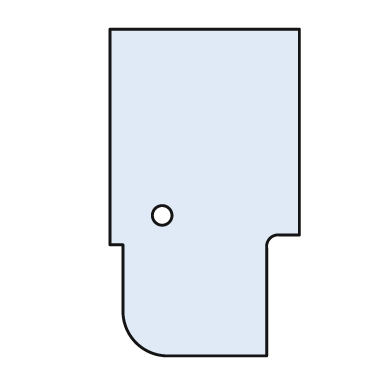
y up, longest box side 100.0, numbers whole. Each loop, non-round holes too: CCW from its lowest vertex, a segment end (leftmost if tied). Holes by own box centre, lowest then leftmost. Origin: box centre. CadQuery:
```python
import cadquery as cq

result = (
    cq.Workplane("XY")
    .moveTo(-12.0, -50.0)
    .lineTo(19.0, -50.0)
    .lineTo(19.0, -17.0)
    .threePointArc((20.0, -14.0), (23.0, -13.0))
    .lineTo(29.0, -13.0)
    .lineTo(29.0, 50.0)
    .lineTo(-29.0, 50.0)
    .lineTo(-29.0, -16.0)
    .lineTo(-25.0, -16.0)
    .lineTo(-25.0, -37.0)
    .threePointArc((-21.0, -46.0), (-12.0, -50.0))
    .close()
    .moveTo(-13.0, -7.0)
    .circle(3.0)
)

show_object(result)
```